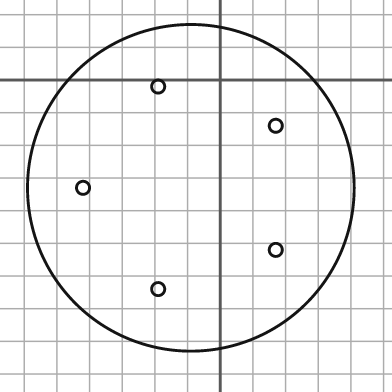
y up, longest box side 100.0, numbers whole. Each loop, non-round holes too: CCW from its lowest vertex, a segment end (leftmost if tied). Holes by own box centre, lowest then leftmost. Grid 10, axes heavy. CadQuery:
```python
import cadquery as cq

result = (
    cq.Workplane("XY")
    .moveTo(-9.0, -33.0)
    .circle(50.0)
    .moveTo(-19.0, -64.0)
    .circle(2.0)
    .moveTo(17.0, -52.0)
    .circle(2.0)
    .moveTo(-42.0, -33.0)
    .circle(2.0)
    .moveTo(17.0, -14.0)
    .circle(2.0)
    .moveTo(-19.0, -2.0)
    .circle(2.0)
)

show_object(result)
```